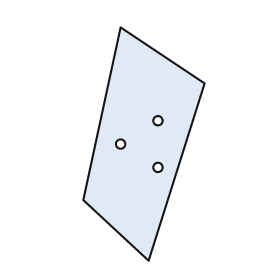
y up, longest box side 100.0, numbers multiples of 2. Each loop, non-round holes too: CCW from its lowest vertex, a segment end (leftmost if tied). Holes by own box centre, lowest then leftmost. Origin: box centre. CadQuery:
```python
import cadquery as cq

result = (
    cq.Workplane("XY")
    .moveTo(2.0, -50.0)
    .lineTo(26.0, 26.0)
    .lineTo(-10.0, 50.0)
    .lineTo(-26.0, -24.0)
    .close()
    .moveTo(6.0, -10.0)
    .circle(2.0)
    .moveTo(-10.0, 0.0)
    .circle(2.0)
    .moveTo(6.0, 10.0)
    .circle(2.0)
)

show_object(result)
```